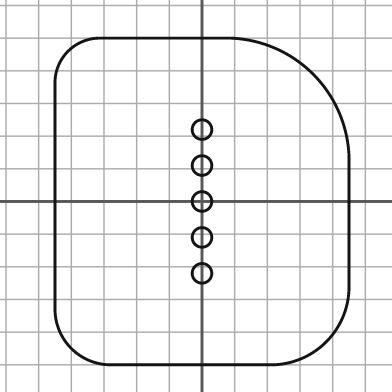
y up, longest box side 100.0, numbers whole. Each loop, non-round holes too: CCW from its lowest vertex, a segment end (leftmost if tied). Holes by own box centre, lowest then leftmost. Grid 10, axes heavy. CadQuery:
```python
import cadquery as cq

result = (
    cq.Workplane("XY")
    .moveTo(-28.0, -50.0)
    .lineTo(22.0, -50.0)
    .threePointArc((38.0, -43.0), (45.0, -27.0))
    .lineTo(45.0, 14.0)
    .threePointArc((34.0, 39.0), (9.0, 50.0))
    .lineTo(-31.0, 50.0)
    .threePointArc((-41.0, 46.0), (-45.0, 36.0))
    .lineTo(-45.0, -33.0)
    .threePointArc((-40.0, -45.0), (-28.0, -50.0))
    .close()
    .moveTo(0.0, -22.0)
    .circle(3.0)
    .moveTo(0.0, -11.0)
    .circle(3.0)
    .moveTo(0.0, 0.0)
    .circle(3.0)
    .moveTo(0.0, 11.0)
    .circle(3.0)
    .moveTo(0.0, 22.0)
    .circle(3.0)
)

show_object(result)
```